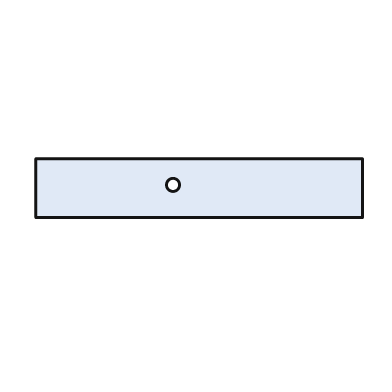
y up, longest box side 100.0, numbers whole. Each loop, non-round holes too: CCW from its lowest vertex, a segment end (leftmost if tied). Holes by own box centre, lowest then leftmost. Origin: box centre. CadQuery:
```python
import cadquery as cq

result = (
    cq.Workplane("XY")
    .moveTo(-50.0, -9.0)
    .lineTo(50.0, -9.0)
    .lineTo(50.0, 9.0)
    .lineTo(-50.0, 9.0)
    .close()
    .moveTo(-8.0, 1.0)
    .circle(2.0)
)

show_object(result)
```